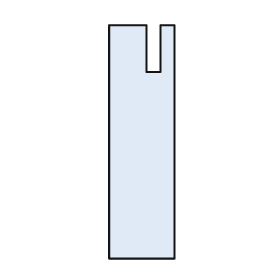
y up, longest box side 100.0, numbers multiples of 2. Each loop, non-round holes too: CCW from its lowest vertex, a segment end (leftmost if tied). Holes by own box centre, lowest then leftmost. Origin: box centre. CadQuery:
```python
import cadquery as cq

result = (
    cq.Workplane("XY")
    .moveTo(-14.0, -50.0)
    .lineTo(14.0, -50.0)
    .lineTo(14.0, 50.0)
    .lineTo(8.0, 50.0)
    .lineTo(8.0, 30.0)
    .lineTo(2.0, 30.0)
    .lineTo(2.0, 50.0)
    .lineTo(-14.0, 50.0)
    .close()
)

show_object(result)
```